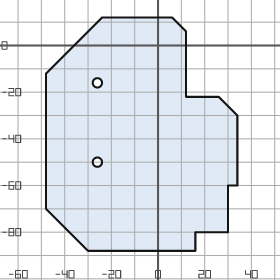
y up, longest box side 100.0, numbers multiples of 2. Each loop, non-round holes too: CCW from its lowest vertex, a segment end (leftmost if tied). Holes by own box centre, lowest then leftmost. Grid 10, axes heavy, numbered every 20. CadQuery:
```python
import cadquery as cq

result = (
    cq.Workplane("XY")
    .moveTo(-30.0, -88.0)
    .lineTo(16.0, -88.0)
    .lineTo(16.0, -80.0)
    .lineTo(30.0, -80.0)
    .lineTo(30.0, -60.0)
    .lineTo(34.0, -60.0)
    .lineTo(34.0, -30.0)
    .lineTo(26.0, -22.0)
    .lineTo(12.0, -22.0)
    .lineTo(12.0, 6.0)
    .lineTo(6.0, 12.0)
    .lineTo(-24.0, 12.0)
    .lineTo(-48.0, -12.0)
    .lineTo(-48.0, -70.0)
    .close()
    .moveTo(-26.0, -50.0)
    .circle(2.0)
    .moveTo(-26.0, -16.0)
    .circle(2.0)
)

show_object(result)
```